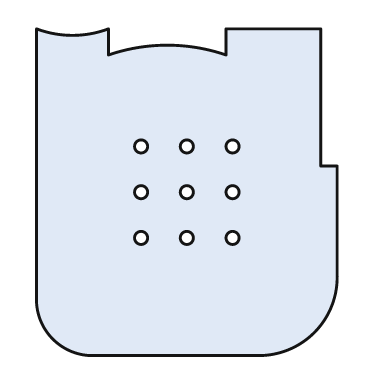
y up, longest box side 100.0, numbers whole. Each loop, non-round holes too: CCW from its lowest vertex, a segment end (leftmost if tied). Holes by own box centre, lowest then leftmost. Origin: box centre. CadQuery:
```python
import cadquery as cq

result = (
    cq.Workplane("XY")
    .moveTo(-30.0, -50.0)
    .lineTo(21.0, -50.0)
    .threePointArc((39.0, -43.0), (46.0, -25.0))
    .lineTo(46.0, 8.0)
    .lineTo(41.0, 8.0)
    .lineTo(41.0, 50.0)
    .lineTo(12.0, 50.0)
    .lineTo(12.0, 42.0)
    .threePointArc((-6.0, 45.0), (-24.0, 42.0))
    .lineTo(-24.0, 50.0)
    .threePointArc((-35.0, 48.0), (-46.0, 50.0))
    .lineTo(-46.0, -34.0)
    .threePointArc((-41.0, -45.0), (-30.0, -50.0))
    .close()
    .moveTo(-14.0, -14.0)
    .circle(2.0)
    .moveTo(0.0, -14.0)
    .circle(2.0)
    .moveTo(14.0, -14.0)
    .circle(2.0)
    .moveTo(-14.0, 0.0)
    .circle(2.0)
    .moveTo(0.0, 0.0)
    .circle(2.0)
    .moveTo(14.0, 0.0)
    .circle(2.0)
    .moveTo(-14.0, 14.0)
    .circle(2.0)
    .moveTo(0.0, 14.0)
    .circle(2.0)
    .moveTo(14.0, 14.0)
    .circle(2.0)
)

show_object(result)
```